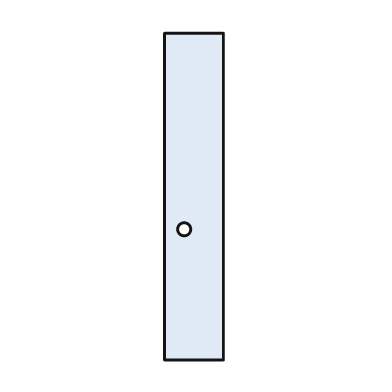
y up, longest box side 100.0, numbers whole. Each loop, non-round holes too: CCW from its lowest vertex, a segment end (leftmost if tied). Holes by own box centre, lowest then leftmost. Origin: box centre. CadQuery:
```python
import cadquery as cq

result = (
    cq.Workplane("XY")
    .moveTo(-9.0, -50.0)
    .lineTo(9.0, -50.0)
    .lineTo(9.0, 50.0)
    .lineTo(-9.0, 50.0)
    .close()
    .moveTo(-3.0, -10.0)
    .circle(2.0)
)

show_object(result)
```